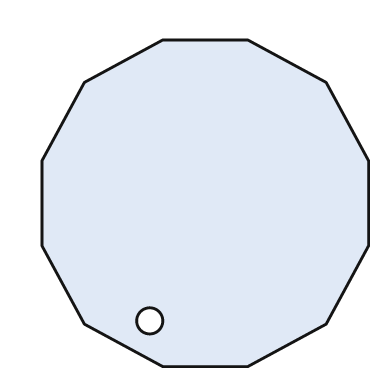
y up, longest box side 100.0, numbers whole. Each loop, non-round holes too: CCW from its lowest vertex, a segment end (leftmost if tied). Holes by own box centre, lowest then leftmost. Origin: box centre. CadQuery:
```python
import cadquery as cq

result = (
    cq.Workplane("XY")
    .moveTo(-13.0, -50.0)
    .lineTo(13.0, -50.0)
    .lineTo(37.0, -37.0)
    .lineTo(50.0, -13.0)
    .lineTo(50.0, 13.0)
    .lineTo(37.0, 37.0)
    .lineTo(13.0, 50.0)
    .lineTo(-13.0, 50.0)
    .lineTo(-37.0, 37.0)
    .lineTo(-50.0, 13.0)
    .lineTo(-50.0, -13.0)
    .lineTo(-37.0, -37.0)
    .close()
    .moveTo(-17.0, -36.0)
    .circle(4.0)
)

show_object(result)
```